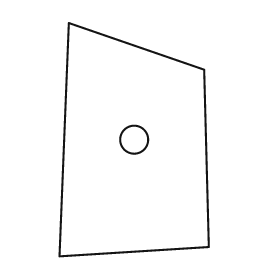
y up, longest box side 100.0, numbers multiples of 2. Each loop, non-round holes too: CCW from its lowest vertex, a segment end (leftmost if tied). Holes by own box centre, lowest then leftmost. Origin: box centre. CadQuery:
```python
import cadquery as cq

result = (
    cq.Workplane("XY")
    .moveTo(-32.0, -50.0)
    .lineTo(32.0, -46.0)
    .lineTo(30.0, 30.0)
    .lineTo(-28.0, 50.0)
    .close()
    .moveTo(0.0, 0.0)
    .circle(6.0)
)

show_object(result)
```